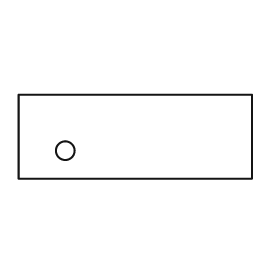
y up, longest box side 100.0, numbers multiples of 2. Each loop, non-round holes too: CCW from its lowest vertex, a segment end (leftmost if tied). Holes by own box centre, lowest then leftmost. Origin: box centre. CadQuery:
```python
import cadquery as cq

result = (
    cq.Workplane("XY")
    .moveTo(-50.0, -18.0)
    .lineTo(50.0, -18.0)
    .lineTo(50.0, 18.0)
    .lineTo(-50.0, 18.0)
    .close()
    .moveTo(-30.0, -6.0)
    .circle(4.0)
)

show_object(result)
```